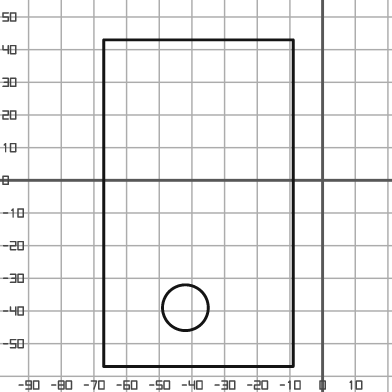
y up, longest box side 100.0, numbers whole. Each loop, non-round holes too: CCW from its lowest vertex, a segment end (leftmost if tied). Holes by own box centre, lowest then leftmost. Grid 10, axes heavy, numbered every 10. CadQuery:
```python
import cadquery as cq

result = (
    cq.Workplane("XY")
    .moveTo(-67.0, -57.0)
    .lineTo(-9.0, -57.0)
    .lineTo(-9.0, 43.0)
    .lineTo(-67.0, 43.0)
    .close()
    .moveTo(-42.0, -39.0)
    .circle(7.0)
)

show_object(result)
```